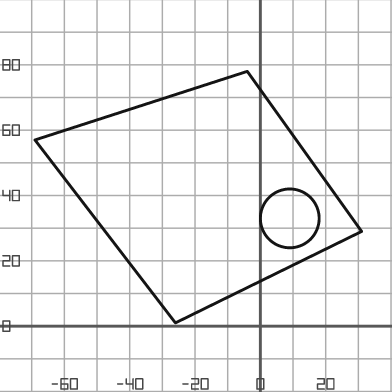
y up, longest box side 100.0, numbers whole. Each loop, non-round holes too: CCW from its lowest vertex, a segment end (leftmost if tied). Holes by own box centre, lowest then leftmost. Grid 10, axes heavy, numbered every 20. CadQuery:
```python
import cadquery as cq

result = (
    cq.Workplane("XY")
    .moveTo(-26.0, 1.0)
    .lineTo(31.0, 29.0)
    .lineTo(-4.0, 78.0)
    .lineTo(-69.0, 57.0)
    .close()
    .moveTo(9.0, 33.0)
    .circle(9.0)
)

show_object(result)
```